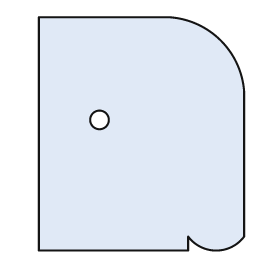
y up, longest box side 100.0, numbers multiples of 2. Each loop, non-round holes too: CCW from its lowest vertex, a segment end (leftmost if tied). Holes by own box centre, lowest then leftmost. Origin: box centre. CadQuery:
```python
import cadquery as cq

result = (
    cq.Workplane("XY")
    .moveTo(-44.0, -50.0)
    .lineTo(20.0, -50.0)
    .lineTo(20.0, -44.0)
    .threePointArc((32.0, -50.0), (44.0, -44.0))
    .lineTo(44.0, 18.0)
    .threePointArc((34.0, 40.0), (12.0, 50.0))
    .lineTo(-44.0, 50.0)
    .close()
    .moveTo(-18.0, 6.0)
    .circle(4.0)
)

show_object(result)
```